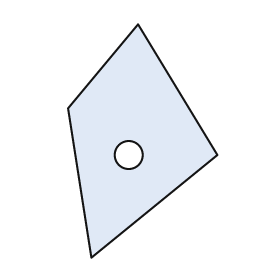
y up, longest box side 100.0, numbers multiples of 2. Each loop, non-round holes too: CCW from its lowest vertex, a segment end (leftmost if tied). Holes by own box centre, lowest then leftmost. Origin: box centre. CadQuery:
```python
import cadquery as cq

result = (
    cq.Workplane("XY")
    .moveTo(-22.0, -50.0)
    .lineTo(32.0, -6.0)
    .lineTo(-2.0, 50.0)
    .lineTo(-32.0, 14.0)
    .close()
    .moveTo(-6.0, -6.0)
    .circle(6.0)
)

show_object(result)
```